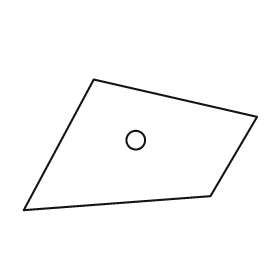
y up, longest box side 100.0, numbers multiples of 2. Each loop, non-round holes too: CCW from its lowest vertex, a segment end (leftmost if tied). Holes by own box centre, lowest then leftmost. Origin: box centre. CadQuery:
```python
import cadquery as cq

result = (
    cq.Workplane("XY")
    .moveTo(-50.0, -28.0)
    .lineTo(30.0, -22.0)
    .lineTo(50.0, 12.0)
    .lineTo(-20.0, 28.0)
    .close()
    .moveTo(-2.0, 2.0)
    .circle(4.0)
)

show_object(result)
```